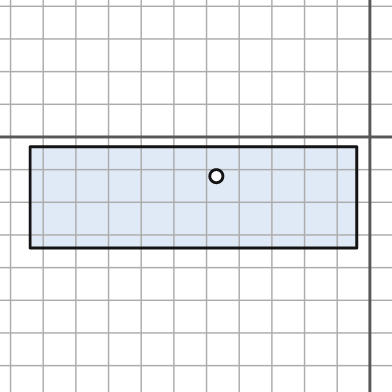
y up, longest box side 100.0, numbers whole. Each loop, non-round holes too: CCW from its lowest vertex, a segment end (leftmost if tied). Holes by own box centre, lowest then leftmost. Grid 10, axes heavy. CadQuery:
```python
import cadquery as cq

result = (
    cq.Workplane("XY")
    .moveTo(-104.0, -34.0)
    .lineTo(-4.0, -34.0)
    .lineTo(-4.0, -3.0)
    .lineTo(-104.0, -3.0)
    .close()
    .moveTo(-47.0, -12.0)
    .circle(2.0)
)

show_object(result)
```